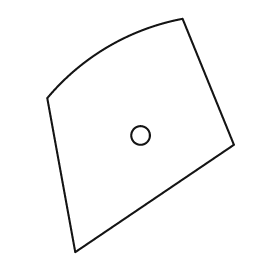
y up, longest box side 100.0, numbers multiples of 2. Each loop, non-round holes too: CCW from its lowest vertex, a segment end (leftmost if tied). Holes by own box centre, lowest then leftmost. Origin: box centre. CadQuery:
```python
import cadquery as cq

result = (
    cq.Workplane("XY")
    .moveTo(-28.0, -50.0)
    .lineTo(40.0, -4.0)
    .lineTo(18.0, 50.0)
    .threePointArc((-14.0, 38.0), (-40.0, 16.0))
    .close()
    .moveTo(0.0, 0.0)
    .circle(4.0)
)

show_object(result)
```